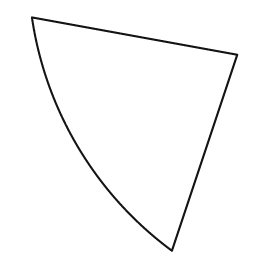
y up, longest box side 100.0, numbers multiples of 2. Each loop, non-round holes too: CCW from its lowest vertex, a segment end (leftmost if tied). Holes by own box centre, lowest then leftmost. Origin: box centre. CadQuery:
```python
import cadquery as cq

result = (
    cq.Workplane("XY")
    .moveTo(16.0, -50.0)
    .lineTo(44.0, 34.0)
    .lineTo(-44.0, 50.0)
    .threePointArc((-24.0, -6.0), (16.0, -50.0))
    .close()
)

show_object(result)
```